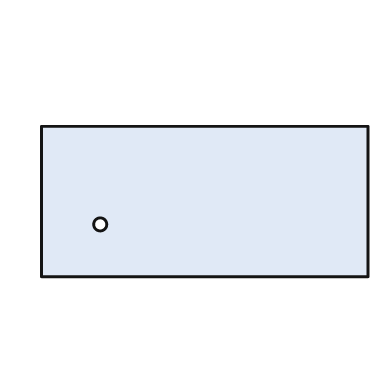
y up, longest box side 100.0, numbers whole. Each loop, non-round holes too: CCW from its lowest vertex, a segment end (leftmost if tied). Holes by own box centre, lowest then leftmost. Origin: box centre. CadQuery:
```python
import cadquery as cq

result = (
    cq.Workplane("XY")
    .moveTo(-50.0, -23.0)
    .lineTo(50.0, -23.0)
    .lineTo(50.0, 23.0)
    .lineTo(-50.0, 23.0)
    .close()
    .moveTo(-32.0, -7.0)
    .circle(2.0)
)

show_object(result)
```